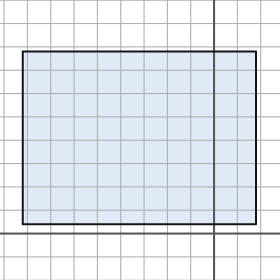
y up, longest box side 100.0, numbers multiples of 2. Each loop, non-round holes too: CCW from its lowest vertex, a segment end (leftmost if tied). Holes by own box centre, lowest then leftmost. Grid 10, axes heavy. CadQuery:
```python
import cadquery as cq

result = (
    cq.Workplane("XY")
    .moveTo(-82.0, 4.0)
    .lineTo(18.0, 4.0)
    .lineTo(18.0, 78.0)
    .lineTo(-82.0, 78.0)
    .close()
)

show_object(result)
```